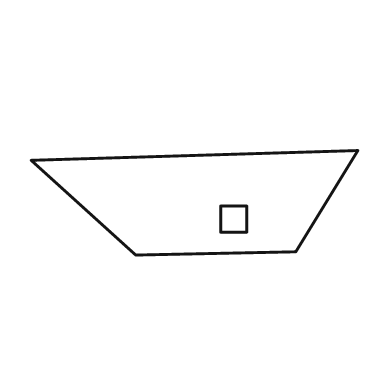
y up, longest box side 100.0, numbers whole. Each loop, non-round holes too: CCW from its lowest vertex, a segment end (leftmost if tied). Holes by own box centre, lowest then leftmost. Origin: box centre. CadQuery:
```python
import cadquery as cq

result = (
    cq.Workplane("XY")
    .moveTo(-18.0, -16.0)
    .lineTo(31.0, -15.0)
    .lineTo(50.0, 16.0)
    .lineTo(-50.0, 13.0)
    .close()
    .moveTo(8.0, -9.0)
    .lineTo(16.0, -9.0)
    .lineTo(16.0, -1.0)
    .lineTo(8.0, -1.0)
    .close()
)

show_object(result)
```